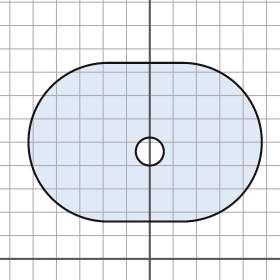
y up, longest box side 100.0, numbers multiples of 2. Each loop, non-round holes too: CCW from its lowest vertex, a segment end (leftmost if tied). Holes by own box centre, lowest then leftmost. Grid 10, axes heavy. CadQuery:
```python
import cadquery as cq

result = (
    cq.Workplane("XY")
    .moveTo(-18.0, 16.0)
    .lineTo(14.0, 16.0)
    .threePointArc((48.0, 50.0), (14.0, 84.0))
    .lineTo(-18.0, 84.0)
    .threePointArc((-52.0, 50.0), (-18.0, 16.0))
    .close()
    .moveTo(0.0, 46.0)
    .circle(6.0)
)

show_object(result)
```